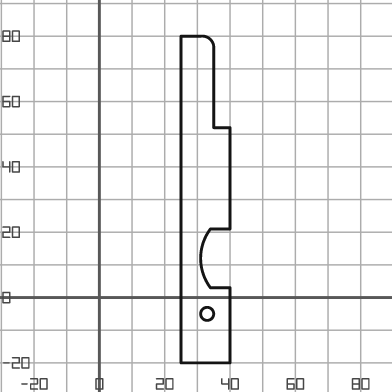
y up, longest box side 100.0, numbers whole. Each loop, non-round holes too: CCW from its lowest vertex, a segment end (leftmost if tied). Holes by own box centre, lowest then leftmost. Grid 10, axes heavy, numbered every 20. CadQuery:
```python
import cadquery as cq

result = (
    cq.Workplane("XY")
    .moveTo(25.0, -20.0)
    .lineTo(40.0, -20.0)
    .lineTo(40.0, 3.0)
    .lineTo(34.0, 3.0)
    .threePointArc((31.0, 12.0), (34.0, 21.0))
    .lineTo(40.0, 21.0)
    .lineTo(40.0, 52.0)
    .lineTo(35.0, 52.0)
    .lineTo(35.0, 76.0)
    .threePointArc((34.0, 79.0), (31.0, 80.0))
    .lineTo(25.0, 80.0)
    .close()
    .moveTo(33.0, -5.0)
    .circle(2.0)
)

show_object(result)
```